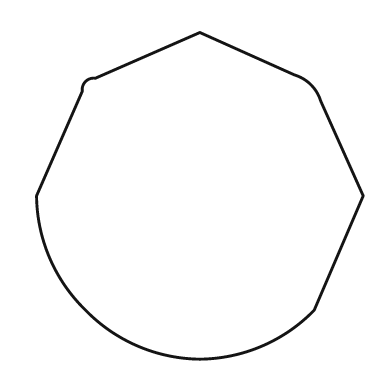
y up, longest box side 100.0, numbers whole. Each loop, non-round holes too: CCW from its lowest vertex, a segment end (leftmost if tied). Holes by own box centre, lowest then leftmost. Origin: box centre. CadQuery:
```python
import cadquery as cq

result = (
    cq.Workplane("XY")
    .moveTo(0.0, -50.0)
    .threePointArc((19.0, -46.0), (35.0, -35.0))
    .lineTo(50.0, 0.0)
    .lineTo(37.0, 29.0)
    .threePointArc((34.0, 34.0), (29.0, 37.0))
    .lineTo(0.0, 50.0)
    .lineTo(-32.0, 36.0)
    .threePointArc((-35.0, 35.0), (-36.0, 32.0))
    .lineTo(-50.0, 0.0)
    .threePointArc((-46.0, -19.0), (-35.0, -35.0))
    .threePointArc((-19.0, -46.0), (0.0, -50.0))
    .close()
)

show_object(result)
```